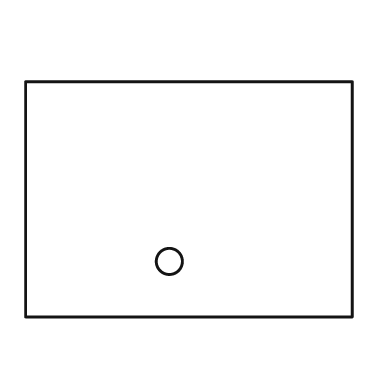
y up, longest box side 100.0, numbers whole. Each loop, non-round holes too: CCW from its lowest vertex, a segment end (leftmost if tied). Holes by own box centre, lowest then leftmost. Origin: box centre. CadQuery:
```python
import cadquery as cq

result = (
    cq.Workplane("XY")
    .moveTo(-50.0, -36.0)
    .lineTo(50.0, -36.0)
    .lineTo(50.0, 36.0)
    .lineTo(-50.0, 36.0)
    .close()
    .moveTo(-6.0, -19.0)
    .circle(4.0)
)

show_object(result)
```